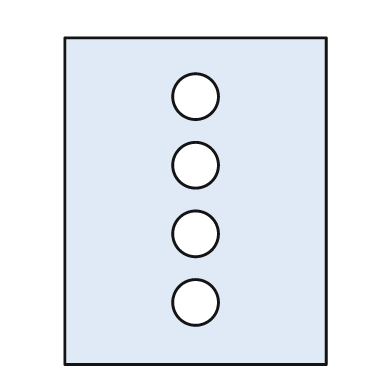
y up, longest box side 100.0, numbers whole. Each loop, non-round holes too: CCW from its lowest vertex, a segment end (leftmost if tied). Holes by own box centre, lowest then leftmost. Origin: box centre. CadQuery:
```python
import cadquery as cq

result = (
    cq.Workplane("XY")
    .moveTo(-40.0, -50.0)
    .lineTo(40.0, -50.0)
    .lineTo(40.0, 50.0)
    .lineTo(-40.0, 50.0)
    .close()
    .moveTo(0.0, -31.0)
    .circle(7.0)
    .moveTo(0.0, -10.0)
    .circle(7.0)
    .moveTo(0.0, 11.0)
    .circle(7.0)
    .moveTo(0.0, 32.0)
    .circle(7.0)
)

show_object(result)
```